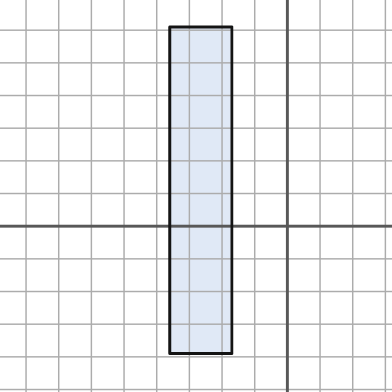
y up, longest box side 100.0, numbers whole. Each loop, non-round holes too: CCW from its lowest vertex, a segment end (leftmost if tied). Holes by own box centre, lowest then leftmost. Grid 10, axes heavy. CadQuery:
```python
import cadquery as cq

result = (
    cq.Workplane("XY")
    .moveTo(-36.0, -39.0)
    .lineTo(-17.0, -39.0)
    .lineTo(-17.0, 61.0)
    .lineTo(-36.0, 61.0)
    .close()
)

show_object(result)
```